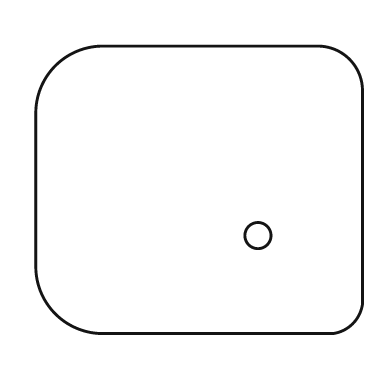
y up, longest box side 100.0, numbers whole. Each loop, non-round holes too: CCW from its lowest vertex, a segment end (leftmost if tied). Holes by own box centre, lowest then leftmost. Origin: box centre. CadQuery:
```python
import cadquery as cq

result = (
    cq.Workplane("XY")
    .moveTo(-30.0, -44.0)
    .lineTo(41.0, -44.0)
    .threePointArc((47.0, -41.0), (50.0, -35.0))
    .lineTo(50.0, 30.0)
    .threePointArc((46.0, 40.0), (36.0, 44.0))
    .lineTo(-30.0, 44.0)
    .threePointArc((-44.0, 38.0), (-50.0, 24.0))
    .lineTo(-50.0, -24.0)
    .threePointArc((-44.0, -38.0), (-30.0, -44.0))
    .close()
    .moveTo(18.0, -14.0)
    .circle(4.0)
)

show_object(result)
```